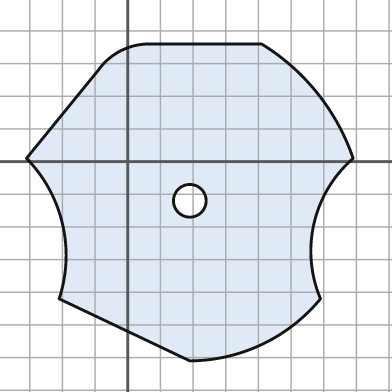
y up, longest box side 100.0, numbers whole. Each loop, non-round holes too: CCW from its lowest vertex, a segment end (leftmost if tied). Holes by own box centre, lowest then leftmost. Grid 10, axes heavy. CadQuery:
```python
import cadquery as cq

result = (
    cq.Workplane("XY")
    .moveTo(19.0, -61.0)
    .threePointArc((41.0, -56.0), (59.0, -42.0))
    .threePointArc((57.0, -19.0), (69.0, 1.0))
    .threePointArc((58.0, 21.0), (41.0, 36.0))
    .lineTo(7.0, 36.0)
    .threePointArc((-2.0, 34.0), (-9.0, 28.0))
    .lineTo(-31.0, 1.0)
    .threePointArc((-20.0, -19.0), (-21.0, -42.0))
    .close()
    .moveTo(19.0, -12.0)
    .circle(5.0)
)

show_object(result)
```